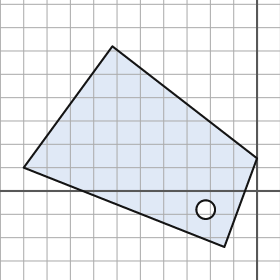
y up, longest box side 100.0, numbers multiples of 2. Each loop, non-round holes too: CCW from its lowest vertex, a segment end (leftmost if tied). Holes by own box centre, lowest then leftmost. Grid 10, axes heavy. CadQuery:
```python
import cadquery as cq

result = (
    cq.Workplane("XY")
    .moveTo(-14.0, -24.0)
    .lineTo(0.0, 14.0)
    .lineTo(-62.0, 62.0)
    .lineTo(-100.0, 10.0)
    .close()
    .moveTo(-22.0, -8.0)
    .circle(4.0)
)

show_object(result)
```